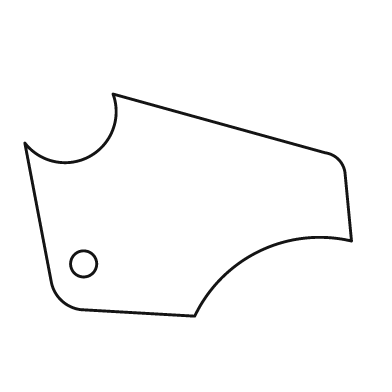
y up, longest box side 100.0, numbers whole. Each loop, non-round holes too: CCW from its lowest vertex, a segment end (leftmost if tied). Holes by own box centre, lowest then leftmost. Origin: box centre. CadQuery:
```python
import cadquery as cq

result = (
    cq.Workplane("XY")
    .moveTo(2.0, -34.0)
    .threePointArc((22.0, -14.0), (50.0, -11.0))
    .lineTo(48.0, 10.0)
    .threePointArc((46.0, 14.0), (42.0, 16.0))
    .lineTo(-23.0, 34.0)
    .threePointArc((-30.0, 15.0), (-50.0, 19.0))
    .lineTo(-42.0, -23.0)
    .threePointArc((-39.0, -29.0), (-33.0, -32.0))
    .close()
    .moveTo(-32.0, -18.0)
    .circle(4.0)
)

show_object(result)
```